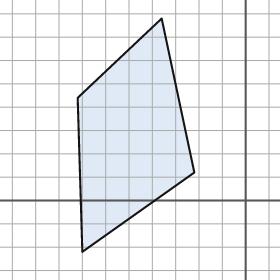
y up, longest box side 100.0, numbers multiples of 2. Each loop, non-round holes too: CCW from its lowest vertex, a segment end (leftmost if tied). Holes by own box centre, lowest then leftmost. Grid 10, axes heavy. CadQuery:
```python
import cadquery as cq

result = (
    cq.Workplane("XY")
    .moveTo(-70.0, -22.0)
    .lineTo(-22.0, 12.0)
    .lineTo(-36.0, 78.0)
    .lineTo(-72.0, 44.0)
    .close()
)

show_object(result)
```